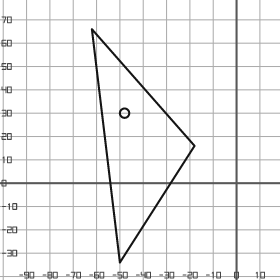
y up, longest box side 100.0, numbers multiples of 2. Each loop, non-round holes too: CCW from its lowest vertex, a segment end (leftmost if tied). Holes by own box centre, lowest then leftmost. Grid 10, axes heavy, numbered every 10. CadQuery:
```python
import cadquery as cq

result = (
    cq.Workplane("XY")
    .moveTo(-50.0, -34.0)
    .lineTo(-18.0, 16.0)
    .lineTo(-62.0, 66.0)
    .close()
    .moveTo(-48.0, 30.0)
    .circle(2.0)
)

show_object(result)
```